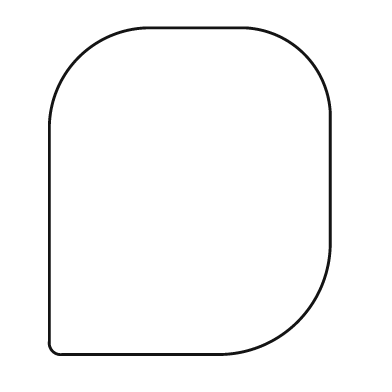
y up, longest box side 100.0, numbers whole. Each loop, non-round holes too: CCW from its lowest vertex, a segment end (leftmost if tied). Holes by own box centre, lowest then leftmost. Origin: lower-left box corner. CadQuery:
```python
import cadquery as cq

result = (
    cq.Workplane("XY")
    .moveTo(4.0, 0.0)
    .lineTo(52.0, 0.0)
    .threePointArc((76.0, 10.0), (86.0, 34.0))
    .lineTo(86.0, 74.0)
    .threePointArc((78.0, 92.0), (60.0, 100.0))
    .lineTo(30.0, 100.0)
    .threePointArc((9.0, 91.0), (0.0, 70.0))
    .lineTo(0.0, 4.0)
    .threePointArc((1.0, 1.0), (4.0, 0.0))
    .close()
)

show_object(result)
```